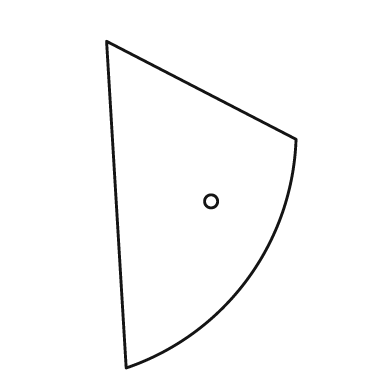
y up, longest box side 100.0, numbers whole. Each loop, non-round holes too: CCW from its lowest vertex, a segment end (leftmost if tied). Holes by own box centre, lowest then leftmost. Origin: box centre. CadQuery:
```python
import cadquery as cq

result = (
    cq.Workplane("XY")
    .moveTo(-23.0, -50.0)
    .threePointArc((14.0, -23.0), (29.0, 20.0))
    .lineTo(-29.0, 50.0)
    .close()
    .moveTo(3.0, 1.0)
    .circle(2.0)
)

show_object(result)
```